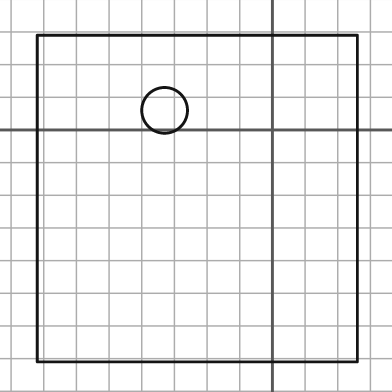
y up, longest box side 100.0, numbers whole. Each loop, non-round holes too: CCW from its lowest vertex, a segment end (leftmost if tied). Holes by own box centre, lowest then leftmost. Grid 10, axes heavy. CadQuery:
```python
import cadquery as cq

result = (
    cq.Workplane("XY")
    .moveTo(-72.0, -71.0)
    .lineTo(26.0, -71.0)
    .lineTo(26.0, 29.0)
    .lineTo(-72.0, 29.0)
    .close()
    .moveTo(-33.0, 6.0)
    .circle(7.0)
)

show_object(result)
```